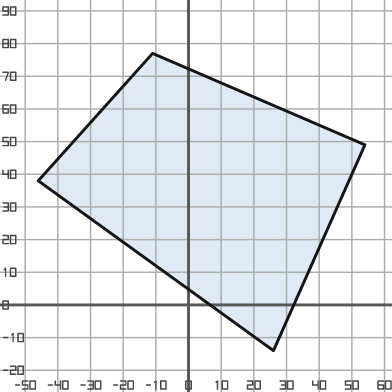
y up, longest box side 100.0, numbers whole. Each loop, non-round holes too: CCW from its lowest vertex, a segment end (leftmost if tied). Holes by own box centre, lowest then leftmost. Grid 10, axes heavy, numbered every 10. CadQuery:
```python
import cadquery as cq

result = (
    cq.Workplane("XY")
    .moveTo(26.0, -14.0)
    .lineTo(54.0, 49.0)
    .lineTo(-11.0, 77.0)
    .lineTo(-46.0, 38.0)
    .close()
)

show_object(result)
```